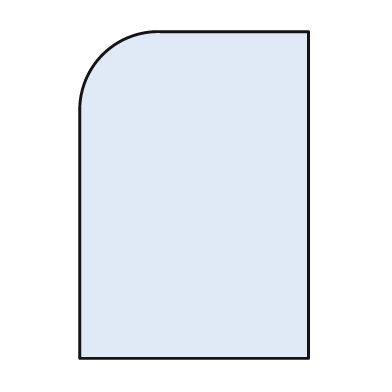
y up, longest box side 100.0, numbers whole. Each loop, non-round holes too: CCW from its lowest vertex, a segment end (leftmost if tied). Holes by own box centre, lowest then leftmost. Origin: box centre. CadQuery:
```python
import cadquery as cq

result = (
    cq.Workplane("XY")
    .moveTo(-35.0, -50.0)
    .lineTo(35.0, -50.0)
    .lineTo(35.0, 50.0)
    .lineTo(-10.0, 50.0)
    .threePointArc((-28.0, 43.0), (-35.0, 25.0))
    .close()
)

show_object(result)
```